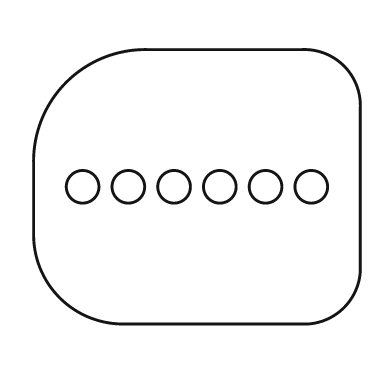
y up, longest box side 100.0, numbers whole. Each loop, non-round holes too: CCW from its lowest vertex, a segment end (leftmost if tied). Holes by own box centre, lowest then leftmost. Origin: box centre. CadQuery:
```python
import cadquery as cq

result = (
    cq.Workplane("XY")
    .moveTo(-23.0, -42.0)
    .lineTo(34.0, -42.0)
    .threePointArc((45.0, -37.0), (50.0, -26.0))
    .lineTo(50.0, 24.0)
    .threePointArc((45.0, 37.0), (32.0, 42.0))
    .lineTo(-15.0, 42.0)
    .threePointArc((-40.0, 32.0), (-50.0, 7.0))
    .lineTo(-50.0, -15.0)
    .threePointArc((-42.0, -34.0), (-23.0, -42.0))
    .close()
    .moveTo(-35.0, 0.0)
    .circle(5.0)
    .moveTo(-21.0, 0.0)
    .circle(5.0)
    .moveTo(-7.0, 0.0)
    .circle(5.0)
    .moveTo(7.0, 0.0)
    .circle(5.0)
    .moveTo(21.0, 0.0)
    .circle(5.0)
    .moveTo(35.0, 0.0)
    .circle(5.0)
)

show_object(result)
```